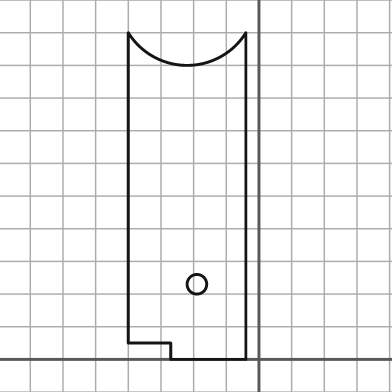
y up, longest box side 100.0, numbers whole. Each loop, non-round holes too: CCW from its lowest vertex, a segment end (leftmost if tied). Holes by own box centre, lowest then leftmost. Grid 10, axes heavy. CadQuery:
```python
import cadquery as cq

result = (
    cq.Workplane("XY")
    .moveTo(-27.0, 0.0)
    .lineTo(-4.0, 0.0)
    .lineTo(-4.0, 100.0)
    .threePointArc((-22.0, 90.0), (-40.0, 100.0))
    .lineTo(-40.0, 5.0)
    .lineTo(-27.0, 5.0)
    .close()
    .moveTo(-19.0, 23.0)
    .circle(3.0)
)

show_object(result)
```